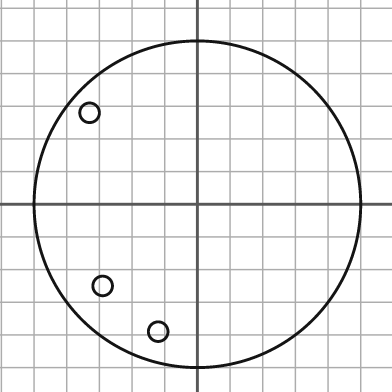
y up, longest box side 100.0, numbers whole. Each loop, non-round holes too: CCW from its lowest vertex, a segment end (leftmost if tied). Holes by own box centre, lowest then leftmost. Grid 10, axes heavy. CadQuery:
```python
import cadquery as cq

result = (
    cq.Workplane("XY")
    .moveTo(0.0, 0.0)
    .circle(50.0)
    .moveTo(-12.0, -39.0)
    .circle(3.0)
    .moveTo(-29.0, -25.0)
    .circle(3.0)
    .moveTo(-33.0, 28.0)
    .circle(3.0)
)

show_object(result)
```